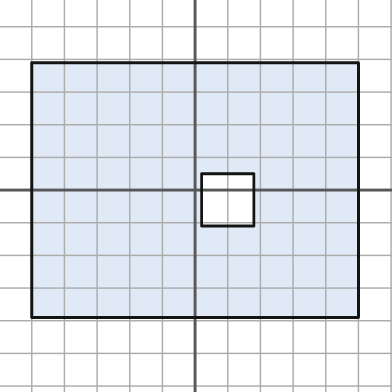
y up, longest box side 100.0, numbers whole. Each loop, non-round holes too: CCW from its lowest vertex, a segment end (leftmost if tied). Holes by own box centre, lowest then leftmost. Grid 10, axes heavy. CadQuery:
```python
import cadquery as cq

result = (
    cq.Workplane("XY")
    .moveTo(-50.0, -39.0)
    .lineTo(50.0, -39.0)
    .lineTo(50.0, 39.0)
    .lineTo(-50.0, 39.0)
    .close()
    .moveTo(2.0, -11.0)
    .lineTo(18.0, -11.0)
    .lineTo(18.0, 5.0)
    .lineTo(2.0, 5.0)
    .close()
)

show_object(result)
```